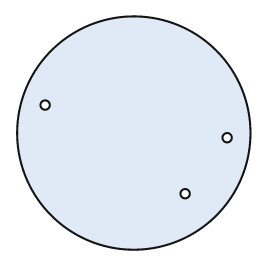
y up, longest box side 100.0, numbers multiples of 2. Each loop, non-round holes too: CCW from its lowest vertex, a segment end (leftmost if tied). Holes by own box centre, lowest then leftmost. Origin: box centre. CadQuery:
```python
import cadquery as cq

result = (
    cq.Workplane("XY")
    .moveTo(0.0, 0.0)
    .circle(50.0)
    .moveTo(22.0, -26.0)
    .circle(2.0)
    .moveTo(40.0, -2.0)
    .circle(2.0)
    .moveTo(-38.0, 12.0)
    .circle(2.0)
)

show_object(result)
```